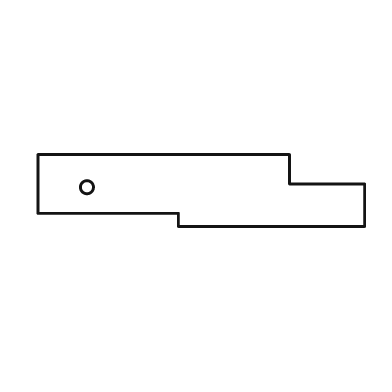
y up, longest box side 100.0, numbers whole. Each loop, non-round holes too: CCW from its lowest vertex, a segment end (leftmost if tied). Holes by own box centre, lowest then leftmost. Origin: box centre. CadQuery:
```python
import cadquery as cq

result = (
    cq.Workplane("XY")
    .moveTo(-7.0, -11.0)
    .lineTo(50.0, -11.0)
    .lineTo(50.0, 2.0)
    .lineTo(27.0, 2.0)
    .lineTo(27.0, 11.0)
    .lineTo(-50.0, 11.0)
    .lineTo(-50.0, -7.0)
    .lineTo(-7.0, -7.0)
    .close()
    .moveTo(-35.0, 1.0)
    .circle(2.0)
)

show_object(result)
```